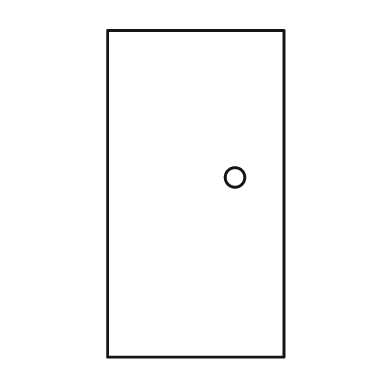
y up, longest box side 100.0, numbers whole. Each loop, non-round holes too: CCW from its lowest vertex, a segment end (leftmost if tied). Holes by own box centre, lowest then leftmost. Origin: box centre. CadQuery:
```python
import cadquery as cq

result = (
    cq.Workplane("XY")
    .moveTo(-27.0, -50.0)
    .lineTo(27.0, -50.0)
    .lineTo(27.0, 50.0)
    .lineTo(-27.0, 50.0)
    .close()
    .moveTo(12.0, 5.0)
    .circle(3.0)
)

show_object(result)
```